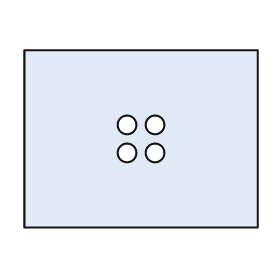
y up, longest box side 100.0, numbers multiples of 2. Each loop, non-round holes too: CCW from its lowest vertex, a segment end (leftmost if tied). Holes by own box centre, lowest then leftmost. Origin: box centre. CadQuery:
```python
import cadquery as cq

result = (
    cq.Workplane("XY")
    .moveTo(-50.0, -38.0)
    .lineTo(50.0, -38.0)
    .lineTo(50.0, 38.0)
    .lineTo(-50.0, 38.0)
    .close()
    .moveTo(-6.0, -6.0)
    .circle(4.0)
    .moveTo(6.0, -6.0)
    .circle(4.0)
    .moveTo(-6.0, 6.0)
    .circle(4.0)
    .moveTo(6.0, 6.0)
    .circle(4.0)
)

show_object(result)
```